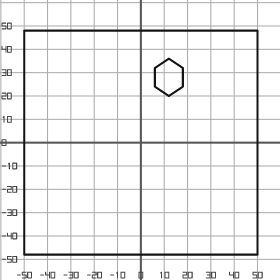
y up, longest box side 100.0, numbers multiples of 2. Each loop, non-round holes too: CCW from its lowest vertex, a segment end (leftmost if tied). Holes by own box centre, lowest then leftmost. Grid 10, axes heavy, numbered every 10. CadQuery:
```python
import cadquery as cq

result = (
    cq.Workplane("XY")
    .moveTo(-50.0, -48.0)
    .lineTo(50.0, -48.0)
    .lineTo(50.0, 48.0)
    .lineTo(-50.0, 48.0)
    .close()
    .moveTo(12.0, 20.0)
    .lineTo(18.0, 24.0)
    .lineTo(18.0, 32.0)
    .lineTo(12.0, 36.0)
    .lineTo(6.0, 32.0)
    .lineTo(6.0, 24.0)
    .close()
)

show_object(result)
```